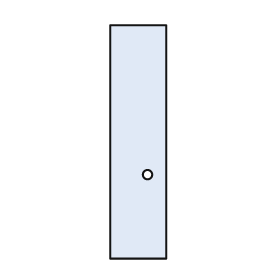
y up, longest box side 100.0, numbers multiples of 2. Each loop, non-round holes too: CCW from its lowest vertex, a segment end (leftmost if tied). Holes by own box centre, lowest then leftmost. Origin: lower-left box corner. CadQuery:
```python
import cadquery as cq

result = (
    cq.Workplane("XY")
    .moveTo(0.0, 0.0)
    .lineTo(24.0, 0.0)
    .lineTo(24.0, 100.0)
    .lineTo(0.0, 100.0)
    .close()
    .moveTo(16.0, 36.0)
    .circle(2.0)
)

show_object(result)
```